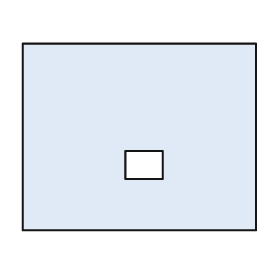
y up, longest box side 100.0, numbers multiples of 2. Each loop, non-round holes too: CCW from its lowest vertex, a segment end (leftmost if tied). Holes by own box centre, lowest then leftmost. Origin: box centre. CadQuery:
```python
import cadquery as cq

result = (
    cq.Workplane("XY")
    .moveTo(-50.0, -40.0)
    .lineTo(50.0, -40.0)
    .lineTo(50.0, 40.0)
    .lineTo(-50.0, 40.0)
    .close()
    .moveTo(-6.0, -18.0)
    .lineTo(10.0, -18.0)
    .lineTo(10.0, -6.0)
    .lineTo(-6.0, -6.0)
    .close()
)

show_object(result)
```